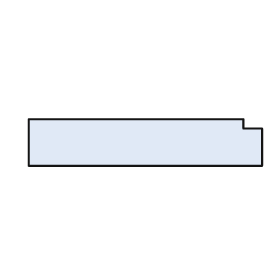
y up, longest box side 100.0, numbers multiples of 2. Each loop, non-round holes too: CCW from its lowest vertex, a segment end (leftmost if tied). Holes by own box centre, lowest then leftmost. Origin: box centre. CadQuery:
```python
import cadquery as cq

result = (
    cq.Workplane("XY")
    .moveTo(-50.0, -10.0)
    .lineTo(50.0, -10.0)
    .lineTo(50.0, 6.0)
    .lineTo(42.0, 6.0)
    .lineTo(42.0, 10.0)
    .lineTo(-50.0, 10.0)
    .close()
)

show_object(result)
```